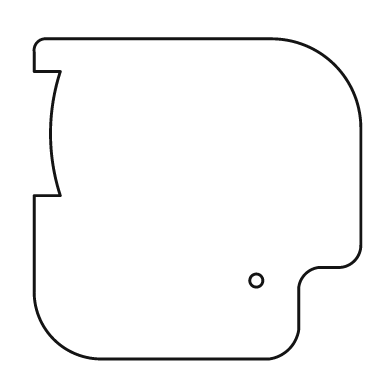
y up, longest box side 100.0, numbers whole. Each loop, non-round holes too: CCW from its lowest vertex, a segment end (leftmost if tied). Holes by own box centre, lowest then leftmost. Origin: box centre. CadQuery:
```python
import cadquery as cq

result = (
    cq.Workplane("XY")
    .moveTo(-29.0, -49.0)
    .lineTo(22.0, -49.0)
    .threePointArc((28.0, -46.0), (31.0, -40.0))
    .lineTo(31.0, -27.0)
    .threePointArc((33.0, -23.0), (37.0, -21.0))
    .lineTo(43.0, -21.0)
    .threePointArc((48.0, -19.0), (50.0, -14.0))
    .lineTo(50.0, 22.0)
    .threePointArc((42.0, 41.0), (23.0, 49.0))
    .lineTo(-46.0, 49.0)
    .threePointArc((-49.0, 48.0), (-50.0, 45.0))
    .lineTo(-50.0, 39.0)
    .lineTo(-42.0, 39.0)
    .threePointArc((-45.0, 20.0), (-42.0, 1.0))
    .lineTo(-50.0, 1.0)
    .lineTo(-50.0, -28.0)
    .threePointArc((-44.0, -43.0), (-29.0, -49.0))
    .close()
    .moveTo(18.0, -25.0)
    .circle(2.0)
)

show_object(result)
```